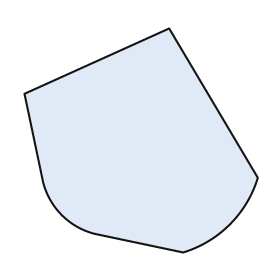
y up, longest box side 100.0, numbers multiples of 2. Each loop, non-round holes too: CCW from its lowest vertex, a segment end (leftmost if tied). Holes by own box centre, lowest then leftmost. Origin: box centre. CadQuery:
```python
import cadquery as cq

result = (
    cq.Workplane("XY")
    .moveTo(18.0, -48.0)
    .threePointArc((38.0, -36.0), (50.0, -16.0))
    .lineTo(12.0, 48.0)
    .lineTo(-50.0, 20.0)
    .lineTo(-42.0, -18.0)
    .threePointArc((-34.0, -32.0), (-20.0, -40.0))
    .close()
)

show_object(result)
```